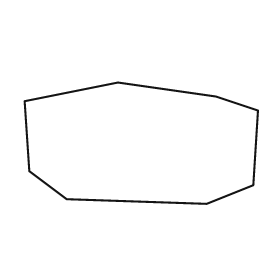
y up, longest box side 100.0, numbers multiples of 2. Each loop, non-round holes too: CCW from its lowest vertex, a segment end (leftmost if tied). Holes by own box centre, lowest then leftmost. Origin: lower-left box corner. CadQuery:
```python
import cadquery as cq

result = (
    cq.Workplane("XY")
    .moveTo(78.0, 0.0)
    .lineTo(98.0, 8.0)
    .lineTo(100.0, 40.0)
    .lineTo(82.0, 46.0)
    .lineTo(40.0, 52.0)
    .lineTo(0.0, 44.0)
    .lineTo(2.0, 14.0)
    .lineTo(18.0, 2.0)
    .close()
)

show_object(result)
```